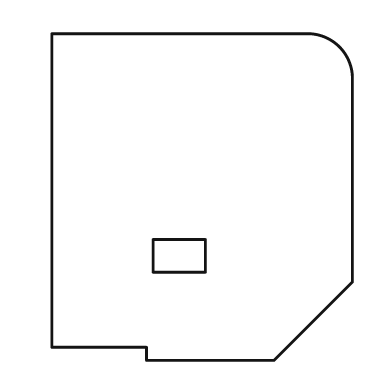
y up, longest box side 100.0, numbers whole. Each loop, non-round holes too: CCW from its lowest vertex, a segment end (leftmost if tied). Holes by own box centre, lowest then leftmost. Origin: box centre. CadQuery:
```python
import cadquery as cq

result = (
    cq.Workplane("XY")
    .moveTo(-17.0, -50.0)
    .lineTo(22.0, -50.0)
    .lineTo(46.0, -26.0)
    .lineTo(46.0, 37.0)
    .threePointArc((42.0, 46.0), (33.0, 50.0))
    .lineTo(-46.0, 50.0)
    .lineTo(-46.0, -46.0)
    .lineTo(-17.0, -46.0)
    .close()
    .moveTo(-15.0, -23.0)
    .lineTo(1.0, -23.0)
    .lineTo(1.0, -13.0)
    .lineTo(-15.0, -13.0)
    .close()
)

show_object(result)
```